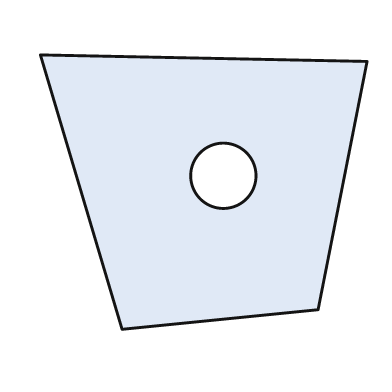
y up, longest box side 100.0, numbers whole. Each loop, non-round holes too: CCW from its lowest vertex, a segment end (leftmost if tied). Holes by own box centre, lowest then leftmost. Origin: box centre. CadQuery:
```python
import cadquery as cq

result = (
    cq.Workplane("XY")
    .moveTo(-25.0, -42.0)
    .lineTo(35.0, -36.0)
    .lineTo(50.0, 40.0)
    .lineTo(-50.0, 42.0)
    .close()
    .moveTo(6.0, 5.0)
    .circle(10.0)
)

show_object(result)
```